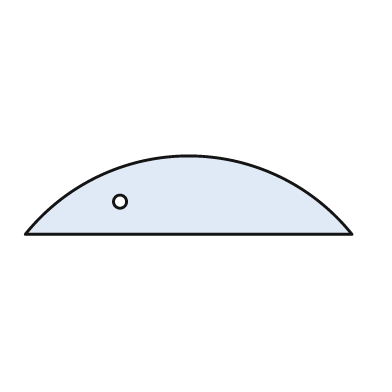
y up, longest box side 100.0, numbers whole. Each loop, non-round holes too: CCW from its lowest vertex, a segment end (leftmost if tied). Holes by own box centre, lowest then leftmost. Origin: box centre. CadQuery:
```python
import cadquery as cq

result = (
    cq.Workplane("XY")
    .moveTo(-50.0, -12.0)
    .lineTo(50.0, -12.0)
    .threePointArc((0.0, 12.0), (-50.0, -12.0))
    .close()
    .moveTo(-21.0, -2.0)
    .circle(2.0)
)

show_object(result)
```